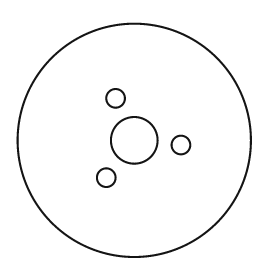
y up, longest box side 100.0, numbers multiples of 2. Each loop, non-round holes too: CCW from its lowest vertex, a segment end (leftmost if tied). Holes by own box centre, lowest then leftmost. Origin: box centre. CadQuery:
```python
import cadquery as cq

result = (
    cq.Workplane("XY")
    .moveTo(0.0, 0.0)
    .circle(50.0)
    .moveTo(-12.0, -16.0)
    .circle(4.0)
    .moveTo(20.0, -2.0)
    .circle(4.0)
    .moveTo(0.0, 0.0)
    .circle(10.0)
    .moveTo(-8.0, 18.0)
    .circle(4.0)
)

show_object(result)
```